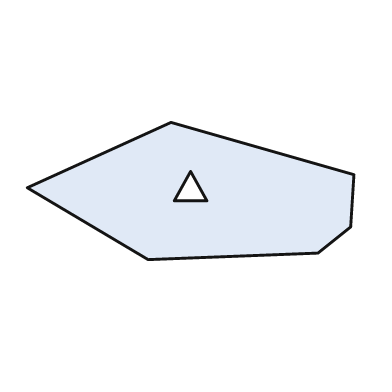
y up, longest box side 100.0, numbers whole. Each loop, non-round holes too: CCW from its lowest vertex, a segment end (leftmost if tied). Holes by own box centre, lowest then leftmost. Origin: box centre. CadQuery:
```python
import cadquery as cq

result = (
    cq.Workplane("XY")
    .moveTo(-13.0, -21.0)
    .lineTo(39.0, -19.0)
    .lineTo(49.0, -11.0)
    .lineTo(50.0, 5.0)
    .lineTo(-6.0, 21.0)
    .lineTo(-50.0, 1.0)
    .close()
    .moveTo(-5.0, -3.0)
    .lineTo(5.0, -3.0)
    .lineTo(0.0, 6.0)
    .close()
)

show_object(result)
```